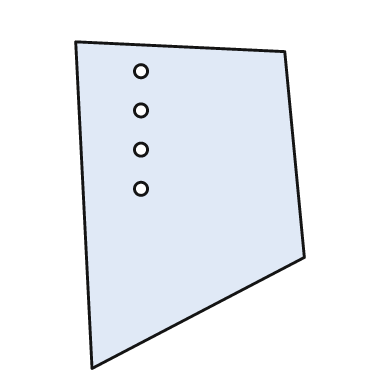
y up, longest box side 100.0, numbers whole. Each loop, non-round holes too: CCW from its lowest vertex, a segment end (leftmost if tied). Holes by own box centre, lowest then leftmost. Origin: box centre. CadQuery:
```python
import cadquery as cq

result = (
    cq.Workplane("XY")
    .moveTo(-30.0, -50.0)
    .lineTo(35.0, -16.0)
    .lineTo(29.0, 47.0)
    .lineTo(-35.0, 50.0)
    .close()
    .moveTo(-15.0, 5.0)
    .circle(2.0)
    .moveTo(-15.0, 17.0)
    .circle(2.0)
    .moveTo(-15.0, 29.0)
    .circle(2.0)
    .moveTo(-15.0, 41.0)
    .circle(2.0)
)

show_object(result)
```